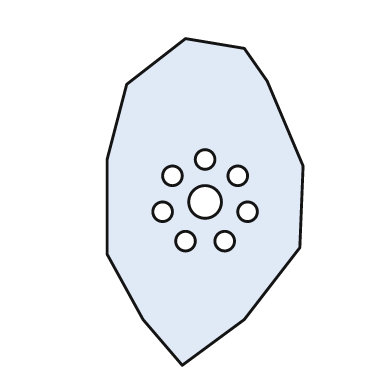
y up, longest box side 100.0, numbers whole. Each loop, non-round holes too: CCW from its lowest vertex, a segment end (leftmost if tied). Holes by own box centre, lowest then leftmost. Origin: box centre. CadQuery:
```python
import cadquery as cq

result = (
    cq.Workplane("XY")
    .moveTo(-7.0, -50.0)
    .lineTo(12.0, -36.0)
    .lineTo(29.0, -14.0)
    .lineTo(30.0, 11.0)
    .lineTo(19.0, 37.0)
    .lineTo(12.0, 47.0)
    .lineTo(-6.0, 50.0)
    .lineTo(-24.0, 36.0)
    .lineTo(-30.0, 13.0)
    .lineTo(-30.0, -16.0)
    .lineTo(-19.0, -36.0)
    .close()
    .moveTo(-6.0, -12.0)
    .circle(3.0)
    .moveTo(6.0, -12.0)
    .circle(3.0)
    .moveTo(-13.0, -3.0)
    .circle(3.0)
    .moveTo(13.0, -3.0)
    .circle(3.0)
    .moveTo(0.0, 0.0)
    .circle(5.0)
    .moveTo(-10.0, 8.0)
    .circle(3.0)
    .moveTo(10.0, 8.0)
    .circle(3.0)
    .moveTo(0.0, 13.0)
    .circle(3.0)
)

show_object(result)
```